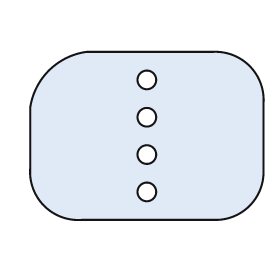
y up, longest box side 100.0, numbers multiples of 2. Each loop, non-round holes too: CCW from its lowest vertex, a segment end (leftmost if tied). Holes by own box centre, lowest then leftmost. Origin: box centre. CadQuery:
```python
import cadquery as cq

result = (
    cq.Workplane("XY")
    .moveTo(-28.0, -36.0)
    .lineTo(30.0, -36.0)
    .threePointArc((44.0, -30.0), (50.0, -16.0))
    .lineTo(50.0, 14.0)
    .threePointArc((44.0, 30.0), (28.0, 36.0))
    .lineTo(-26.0, 36.0)
    .threePointArc((-42.0, 28.0), (-50.0, 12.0))
    .lineTo(-50.0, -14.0)
    .threePointArc((-44.0, -30.0), (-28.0, -36.0))
    .close()
    .moveTo(0.0, -24.0)
    .circle(4.0)
    .moveTo(0.0, -8.0)
    .circle(4.0)
    .moveTo(0.0, 8.0)
    .circle(4.0)
    .moveTo(0.0, 24.0)
    .circle(4.0)
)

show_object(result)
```